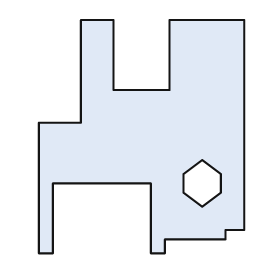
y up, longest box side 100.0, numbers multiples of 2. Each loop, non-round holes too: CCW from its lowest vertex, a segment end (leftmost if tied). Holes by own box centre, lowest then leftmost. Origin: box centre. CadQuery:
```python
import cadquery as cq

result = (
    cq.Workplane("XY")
    .moveTo(-44.0, -50.0)
    .lineTo(-38.0, -50.0)
    .lineTo(-38.0, -20.0)
    .lineTo(4.0, -20.0)
    .lineTo(4.0, -50.0)
    .lineTo(10.0, -50.0)
    .lineTo(10.0, -44.0)
    .lineTo(36.0, -44.0)
    .lineTo(36.0, -40.0)
    .lineTo(44.0, -40.0)
    .lineTo(44.0, 50.0)
    .lineTo(12.0, 50.0)
    .lineTo(12.0, 20.0)
    .lineTo(-12.0, 20.0)
    .lineTo(-12.0, 50.0)
    .lineTo(-26.0, 50.0)
    .lineTo(-26.0, 6.0)
    .lineTo(-44.0, 6.0)
    .close()
    .moveTo(26.0, -30.0)
    .lineTo(34.0, -24.0)
    .lineTo(34.0, -16.0)
    .lineTo(26.0, -10.0)
    .lineTo(18.0, -16.0)
    .lineTo(18.0, -24.0)
    .close()
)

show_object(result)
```